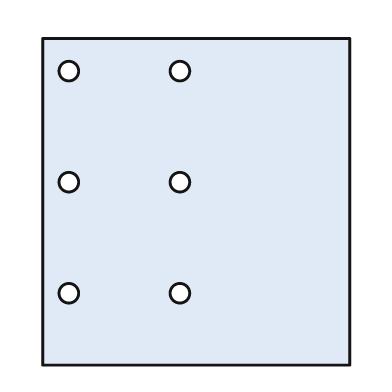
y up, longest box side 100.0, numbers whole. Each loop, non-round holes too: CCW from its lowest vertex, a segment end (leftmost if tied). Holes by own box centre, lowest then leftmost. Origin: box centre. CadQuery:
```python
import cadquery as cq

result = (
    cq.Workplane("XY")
    .moveTo(-47.0, -50.0)
    .lineTo(47.0, -50.0)
    .lineTo(47.0, 50.0)
    .lineTo(-47.0, 50.0)
    .close()
    .moveTo(-39.0, -28.0)
    .circle(3.0)
    .moveTo(-5.0, -28.0)
    .circle(3.0)
    .moveTo(-39.0, 6.0)
    .circle(3.0)
    .moveTo(-5.0, 6.0)
    .circle(3.0)
    .moveTo(-39.0, 40.0)
    .circle(3.0)
    .moveTo(-5.0, 40.0)
    .circle(3.0)
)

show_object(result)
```